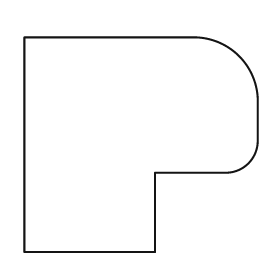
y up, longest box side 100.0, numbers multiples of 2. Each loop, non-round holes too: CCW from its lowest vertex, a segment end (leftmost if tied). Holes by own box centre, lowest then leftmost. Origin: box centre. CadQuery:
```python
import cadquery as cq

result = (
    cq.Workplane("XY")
    .moveTo(-50.0, -46.0)
    .lineTo(6.0, -46.0)
    .lineTo(6.0, -12.0)
    .lineTo(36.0, -12.0)
    .threePointArc((46.0, -8.0), (50.0, 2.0))
    .lineTo(50.0, 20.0)
    .threePointArc((42.0, 38.0), (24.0, 46.0))
    .lineTo(-50.0, 46.0)
    .close()
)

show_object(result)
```